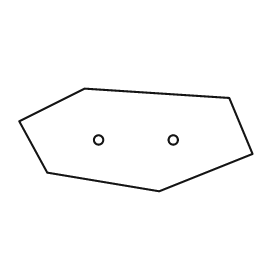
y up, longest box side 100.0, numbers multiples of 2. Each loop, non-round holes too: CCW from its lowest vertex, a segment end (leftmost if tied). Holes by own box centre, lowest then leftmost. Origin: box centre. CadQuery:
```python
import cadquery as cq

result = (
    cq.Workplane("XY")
    .moveTo(10.0, -22.0)
    .lineTo(50.0, -6.0)
    .lineTo(40.0, 18.0)
    .lineTo(-22.0, 22.0)
    .lineTo(-50.0, 8.0)
    .lineTo(-38.0, -14.0)
    .close()
    .moveTo(-16.0, 0.0)
    .circle(2.0)
    .moveTo(16.0, 0.0)
    .circle(2.0)
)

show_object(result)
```